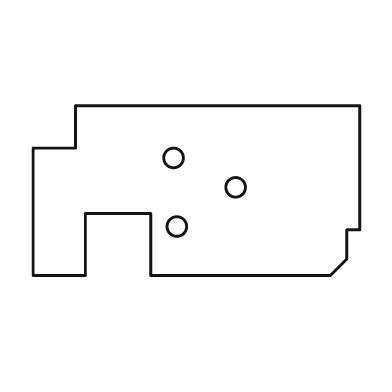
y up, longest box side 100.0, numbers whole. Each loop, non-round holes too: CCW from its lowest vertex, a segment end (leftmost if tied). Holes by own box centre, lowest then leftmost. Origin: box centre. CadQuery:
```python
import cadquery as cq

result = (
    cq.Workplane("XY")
    .moveTo(-50.0, -26.0)
    .lineTo(-34.0, -26.0)
    .lineTo(-34.0, -7.0)
    .lineTo(-14.0, -7.0)
    .lineTo(-14.0, -26.0)
    .lineTo(41.0, -26.0)
    .lineTo(46.0, -21.0)
    .lineTo(46.0, -12.0)
    .lineTo(50.0, -12.0)
    .lineTo(50.0, 26.0)
    .lineTo(-37.0, 26.0)
    .lineTo(-37.0, 13.0)
    .lineTo(-50.0, 13.0)
    .close()
    .moveTo(-6.0, -11.0)
    .circle(3.0)
    .moveTo(12.0, 1.0)
    .circle(3.0)
    .moveTo(-7.0, 10.0)
    .circle(3.0)
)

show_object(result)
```